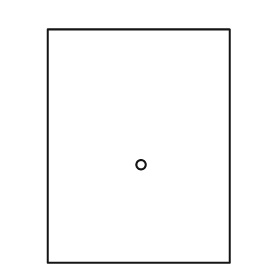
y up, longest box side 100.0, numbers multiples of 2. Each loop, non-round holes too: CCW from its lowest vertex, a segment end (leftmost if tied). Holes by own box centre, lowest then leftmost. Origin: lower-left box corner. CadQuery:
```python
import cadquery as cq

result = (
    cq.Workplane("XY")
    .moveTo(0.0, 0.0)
    .lineTo(78.0, 0.0)
    .lineTo(78.0, 100.0)
    .lineTo(0.0, 100.0)
    .close()
    .moveTo(40.0, 42.0)
    .circle(2.0)
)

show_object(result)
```